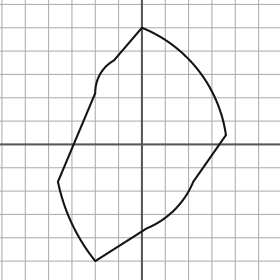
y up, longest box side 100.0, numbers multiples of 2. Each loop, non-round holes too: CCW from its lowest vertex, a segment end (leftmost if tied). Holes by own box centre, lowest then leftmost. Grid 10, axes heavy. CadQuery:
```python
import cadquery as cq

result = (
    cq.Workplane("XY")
    .moveTo(-20.0, -50.0)
    .lineTo(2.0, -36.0)
    .threePointArc((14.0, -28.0), (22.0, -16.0))
    .lineTo(36.0, 4.0)
    .threePointArc((24.0, 32.0), (0.0, 50.0))
    .lineTo(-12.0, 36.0)
    .threePointArc((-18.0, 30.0), (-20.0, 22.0))
    .lineTo(-36.0, -16.0)
    .threePointArc((-30.0, -34.0), (-20.0, -50.0))
    .close()
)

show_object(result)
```